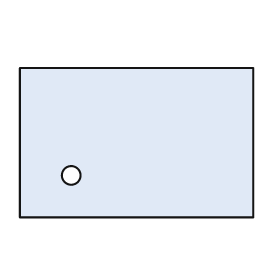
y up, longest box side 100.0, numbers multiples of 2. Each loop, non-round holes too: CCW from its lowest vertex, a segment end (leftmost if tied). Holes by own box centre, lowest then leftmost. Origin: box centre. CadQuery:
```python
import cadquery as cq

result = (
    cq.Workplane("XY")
    .moveTo(-50.0, -32.0)
    .lineTo(50.0, -32.0)
    .lineTo(50.0, 32.0)
    .lineTo(-50.0, 32.0)
    .close()
    .moveTo(-28.0, -14.0)
    .circle(4.0)
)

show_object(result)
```